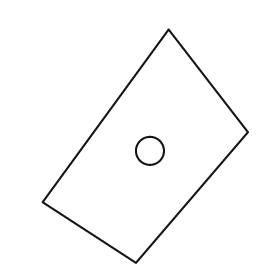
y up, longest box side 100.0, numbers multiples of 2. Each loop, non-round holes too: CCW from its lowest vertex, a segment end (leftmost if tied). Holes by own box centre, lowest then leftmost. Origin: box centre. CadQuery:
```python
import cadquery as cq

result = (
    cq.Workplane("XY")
    .moveTo(-4.0, -50.0)
    .lineTo(44.0, 6.0)
    .lineTo(10.0, 50.0)
    .lineTo(-44.0, -24.0)
    .close()
    .moveTo(2.0, -2.0)
    .circle(6.0)
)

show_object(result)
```